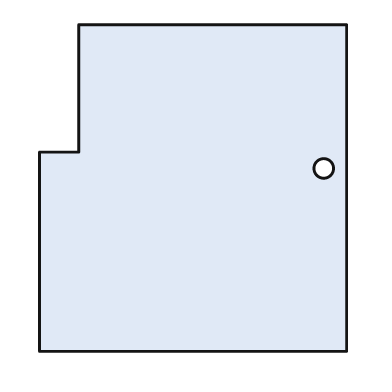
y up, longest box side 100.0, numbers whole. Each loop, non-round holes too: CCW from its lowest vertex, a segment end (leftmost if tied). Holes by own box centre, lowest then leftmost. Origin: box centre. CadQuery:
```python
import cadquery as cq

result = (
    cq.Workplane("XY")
    .moveTo(-47.0, -50.0)
    .lineTo(47.0, -50.0)
    .lineTo(47.0, 50.0)
    .lineTo(-35.0, 50.0)
    .lineTo(-35.0, 11.0)
    .lineTo(-47.0, 11.0)
    .close()
    .moveTo(40.0, 6.0)
    .circle(3.0)
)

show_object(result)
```